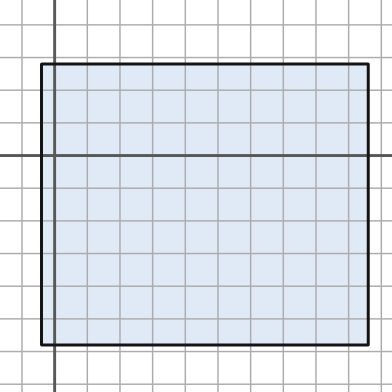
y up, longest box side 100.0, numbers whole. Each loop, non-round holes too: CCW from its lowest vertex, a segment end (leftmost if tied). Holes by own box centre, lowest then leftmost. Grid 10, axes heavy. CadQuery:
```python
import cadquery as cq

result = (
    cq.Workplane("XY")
    .moveTo(-4.0, -58.0)
    .lineTo(96.0, -58.0)
    .lineTo(96.0, 28.0)
    .lineTo(-4.0, 28.0)
    .close()
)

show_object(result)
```